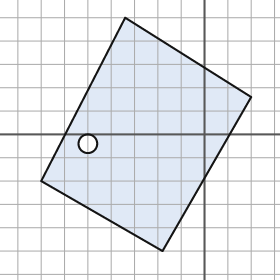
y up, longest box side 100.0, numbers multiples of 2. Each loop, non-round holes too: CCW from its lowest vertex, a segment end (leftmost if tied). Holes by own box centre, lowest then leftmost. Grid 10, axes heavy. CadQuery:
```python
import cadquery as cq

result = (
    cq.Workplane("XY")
    .moveTo(-18.0, -50.0)
    .lineTo(20.0, 16.0)
    .lineTo(-34.0, 50.0)
    .lineTo(-70.0, -20.0)
    .close()
    .moveTo(-50.0, -4.0)
    .circle(4.0)
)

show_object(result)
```